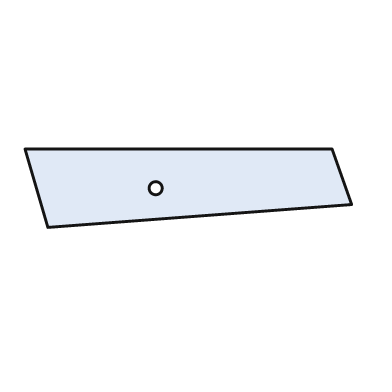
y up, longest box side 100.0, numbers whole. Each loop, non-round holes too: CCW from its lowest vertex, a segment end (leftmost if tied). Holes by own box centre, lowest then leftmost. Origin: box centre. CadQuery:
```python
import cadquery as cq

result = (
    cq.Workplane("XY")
    .moveTo(-43.0, -12.0)
    .lineTo(50.0, -5.0)
    .lineTo(44.0, 12.0)
    .lineTo(-50.0, 12.0)
    .close()
    .moveTo(-10.0, 0.0)
    .circle(2.0)
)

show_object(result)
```